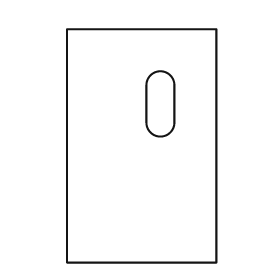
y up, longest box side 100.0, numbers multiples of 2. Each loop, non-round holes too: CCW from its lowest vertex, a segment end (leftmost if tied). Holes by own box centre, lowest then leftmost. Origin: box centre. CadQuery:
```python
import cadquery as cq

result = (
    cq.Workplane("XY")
    .moveTo(-32.0, -50.0)
    .lineTo(32.0, -50.0)
    .lineTo(32.0, 50.0)
    .lineTo(-32.0, 50.0)
    .close()
    .moveTo(2.0, 10.0)
    .threePointArc((8.0, 4.0), (14.0, 10.0))
    .lineTo(14.0, 26.0)
    .threePointArc((8.0, 32.0), (2.0, 26.0))
    .close()
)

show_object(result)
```